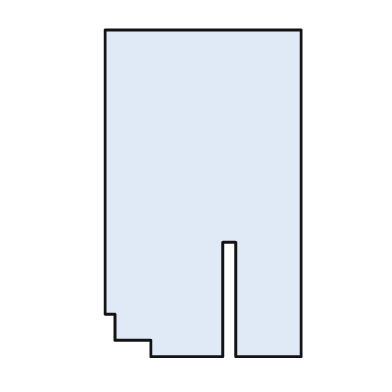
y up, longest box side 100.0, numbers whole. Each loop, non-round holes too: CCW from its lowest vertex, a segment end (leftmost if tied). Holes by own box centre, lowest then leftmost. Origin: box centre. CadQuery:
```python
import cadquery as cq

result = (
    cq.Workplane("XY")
    .moveTo(-16.0, -50.0)
    .lineTo(6.0, -50.0)
    .lineTo(6.0, -15.0)
    .lineTo(10.0, -15.0)
    .lineTo(10.0, -50.0)
    .lineTo(30.0, -50.0)
    .lineTo(30.0, 50.0)
    .lineTo(-30.0, 50.0)
    .lineTo(-30.0, -37.0)
    .lineTo(-27.0, -37.0)
    .lineTo(-27.0, -45.0)
    .lineTo(-16.0, -45.0)
    .close()
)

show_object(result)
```